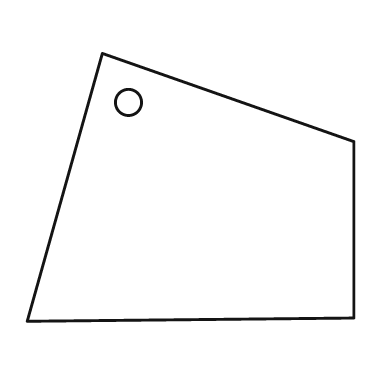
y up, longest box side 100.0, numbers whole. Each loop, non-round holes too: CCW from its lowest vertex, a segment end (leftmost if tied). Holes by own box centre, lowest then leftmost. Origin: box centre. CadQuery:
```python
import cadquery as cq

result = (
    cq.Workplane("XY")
    .moveTo(-50.0, -41.0)
    .lineTo(50.0, -40.0)
    .lineTo(50.0, 14.0)
    .lineTo(-27.0, 41.0)
    .close()
    .moveTo(-19.0, 26.0)
    .circle(4.0)
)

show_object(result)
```